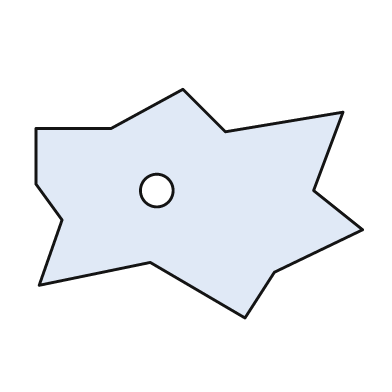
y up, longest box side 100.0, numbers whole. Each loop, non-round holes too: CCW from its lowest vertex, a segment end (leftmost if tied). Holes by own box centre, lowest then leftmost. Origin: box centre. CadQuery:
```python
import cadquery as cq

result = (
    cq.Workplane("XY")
    .moveTo(14.0, -35.0)
    .lineTo(23.0, -21.0)
    .lineTo(50.0, -8.0)
    .lineTo(35.0, 4.0)
    .lineTo(44.0, 28.0)
    .lineTo(8.0, 22.0)
    .lineTo(-5.0, 35.0)
    .lineTo(-27.0, 23.0)
    .lineTo(-50.0, 23.0)
    .lineTo(-50.0, 6.0)
    .lineTo(-42.0, -5.0)
    .lineTo(-49.0, -25.0)
    .lineTo(-15.0, -18.0)
    .close()
    .moveTo(-13.0, 4.0)
    .circle(5.0)
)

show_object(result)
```